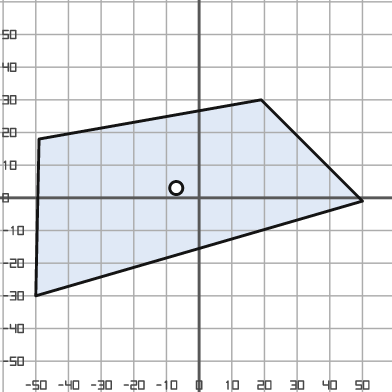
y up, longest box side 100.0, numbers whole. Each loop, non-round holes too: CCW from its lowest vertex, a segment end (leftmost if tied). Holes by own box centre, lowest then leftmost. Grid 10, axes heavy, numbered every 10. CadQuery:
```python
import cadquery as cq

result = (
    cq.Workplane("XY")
    .moveTo(-50.0, -30.0)
    .lineTo(50.0, -1.0)
    .lineTo(19.0, 30.0)
    .lineTo(-49.0, 18.0)
    .close()
    .moveTo(-7.0, 3.0)
    .circle(2.0)
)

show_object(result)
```